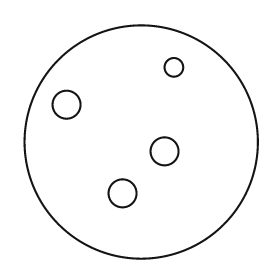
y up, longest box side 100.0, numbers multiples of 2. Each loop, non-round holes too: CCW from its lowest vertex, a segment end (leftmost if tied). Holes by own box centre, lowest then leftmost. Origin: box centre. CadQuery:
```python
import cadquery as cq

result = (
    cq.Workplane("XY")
    .moveTo(0.0, 0.0)
    .circle(50.0)
    .moveTo(-8.0, -22.0)
    .circle(6.0)
    .moveTo(10.0, -4.0)
    .circle(6.0)
    .moveTo(-32.0, 16.0)
    .circle(6.0)
    .moveTo(14.0, 32.0)
    .circle(4.0)
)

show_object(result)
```